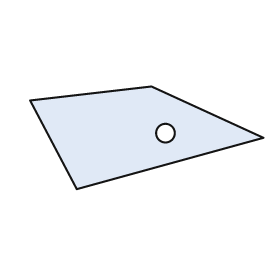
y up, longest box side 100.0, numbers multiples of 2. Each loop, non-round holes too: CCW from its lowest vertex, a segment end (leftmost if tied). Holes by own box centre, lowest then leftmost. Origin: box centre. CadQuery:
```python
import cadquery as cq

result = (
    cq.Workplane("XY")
    .moveTo(-30.0, -22.0)
    .lineTo(50.0, 0.0)
    .lineTo(2.0, 22.0)
    .lineTo(-50.0, 16.0)
    .close()
    .moveTo(8.0, 2.0)
    .circle(4.0)
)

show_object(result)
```